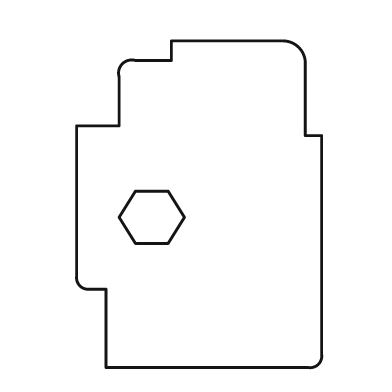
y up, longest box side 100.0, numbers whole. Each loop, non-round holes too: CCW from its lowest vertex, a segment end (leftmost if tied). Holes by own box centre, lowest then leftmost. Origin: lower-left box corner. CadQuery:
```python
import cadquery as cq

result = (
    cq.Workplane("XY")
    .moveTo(9.0, 0.0)
    .lineTo(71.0, 0.0)
    .threePointArc((74.0, 1.0), (75.0, 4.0))
    .lineTo(75.0, 71.0)
    .lineTo(70.0, 71.0)
    .lineTo(70.0, 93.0)
    .threePointArc((68.0, 98.0), (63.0, 100.0))
    .lineTo(29.0, 100.0)
    .lineTo(29.0, 94.0)
    .lineTo(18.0, 94.0)
    .threePointArc((14.0, 93.0), (13.0, 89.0))
    .lineTo(13.0, 74.0)
    .lineTo(0.0, 74.0)
    .lineTo(0.0, 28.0)
    .threePointArc((1.0, 25.0), (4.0, 24.0))
    .lineTo(9.0, 24.0)
    .close()
    .moveTo(18.0, 38.0)
    .lineTo(28.0, 38.0)
    .lineTo(33.0, 46.0)
    .lineTo(28.0, 54.0)
    .lineTo(18.0, 54.0)
    .lineTo(13.0, 46.0)
    .close()
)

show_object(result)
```